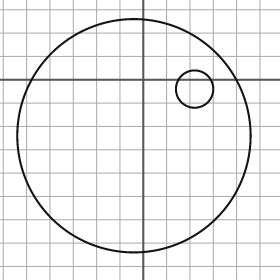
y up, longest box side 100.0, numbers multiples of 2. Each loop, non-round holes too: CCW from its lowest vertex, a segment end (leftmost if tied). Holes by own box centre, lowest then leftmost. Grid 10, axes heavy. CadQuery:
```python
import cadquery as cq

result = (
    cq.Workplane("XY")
    .moveTo(-4.0, -24.0)
    .circle(50.0)
    .moveTo(22.0, -4.0)
    .circle(8.0)
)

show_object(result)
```